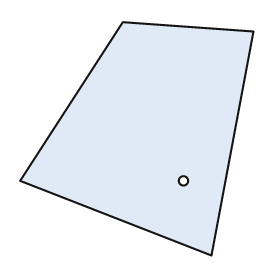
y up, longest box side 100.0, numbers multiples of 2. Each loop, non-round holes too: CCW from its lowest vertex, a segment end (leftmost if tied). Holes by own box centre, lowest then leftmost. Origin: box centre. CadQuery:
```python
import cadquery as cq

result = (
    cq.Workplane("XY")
    .moveTo(32.0, -50.0)
    .lineTo(50.0, 46.0)
    .lineTo(-6.0, 50.0)
    .lineTo(-50.0, -18.0)
    .close()
    .moveTo(20.0, -18.0)
    .circle(2.0)
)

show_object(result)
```